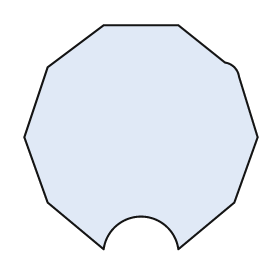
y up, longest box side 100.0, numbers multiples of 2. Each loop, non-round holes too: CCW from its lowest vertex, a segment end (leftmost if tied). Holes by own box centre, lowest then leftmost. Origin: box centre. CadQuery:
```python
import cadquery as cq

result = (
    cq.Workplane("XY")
    .moveTo(-16.0, -48.0)
    .threePointArc((0.0, -34.0), (16.0, -48.0))
    .lineTo(40.0, -28.0)
    .lineTo(50.0, 0.0)
    .lineTo(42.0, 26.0)
    .threePointArc((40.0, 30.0), (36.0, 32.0))
    .lineTo(16.0, 48.0)
    .lineTo(-16.0, 48.0)
    .lineTo(-40.0, 30.0)
    .lineTo(-50.0, 0.0)
    .lineTo(-40.0, -28.0)
    .close()
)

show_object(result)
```